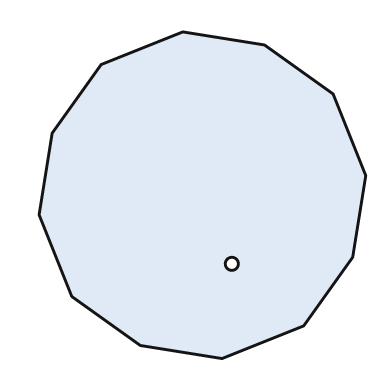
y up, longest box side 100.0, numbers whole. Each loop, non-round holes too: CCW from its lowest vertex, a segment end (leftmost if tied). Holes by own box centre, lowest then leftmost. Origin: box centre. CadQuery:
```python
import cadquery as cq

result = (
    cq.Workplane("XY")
    .moveTo(6.0, -50.0)
    .lineTo(31.0, -40.0)
    .lineTo(46.0, -19.0)
    .lineTo(50.0, 6.0)
    .lineTo(40.0, 31.0)
    .lineTo(19.0, 46.0)
    .lineTo(-6.0, 50.0)
    .lineTo(-31.0, 40.0)
    .lineTo(-46.0, 19.0)
    .lineTo(-50.0, -6.0)
    .lineTo(-40.0, -31.0)
    .lineTo(-19.0, -46.0)
    .close()
    .moveTo(9.0, -21.0)
    .circle(2.0)
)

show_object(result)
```